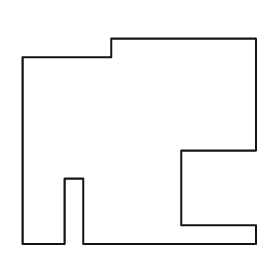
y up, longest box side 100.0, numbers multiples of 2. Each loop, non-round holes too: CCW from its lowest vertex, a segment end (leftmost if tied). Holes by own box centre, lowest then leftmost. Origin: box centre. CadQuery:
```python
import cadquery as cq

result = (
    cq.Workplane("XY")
    .moveTo(-50.0, -44.0)
    .lineTo(-32.0, -44.0)
    .lineTo(-32.0, -16.0)
    .lineTo(-24.0, -16.0)
    .lineTo(-24.0, -44.0)
    .lineTo(50.0, -44.0)
    .lineTo(50.0, -36.0)
    .lineTo(18.0, -36.0)
    .lineTo(18.0, -4.0)
    .lineTo(50.0, -4.0)
    .lineTo(50.0, 44.0)
    .lineTo(-12.0, 44.0)
    .lineTo(-12.0, 36.0)
    .lineTo(-50.0, 36.0)
    .close()
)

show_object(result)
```